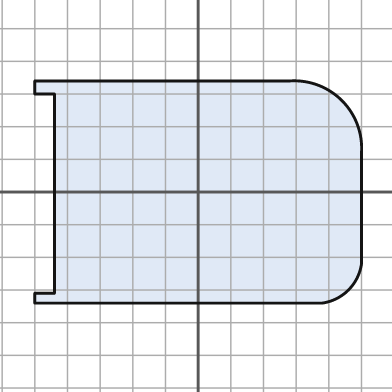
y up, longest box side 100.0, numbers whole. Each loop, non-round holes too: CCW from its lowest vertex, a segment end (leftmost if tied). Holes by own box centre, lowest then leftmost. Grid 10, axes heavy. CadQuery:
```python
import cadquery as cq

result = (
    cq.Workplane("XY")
    .moveTo(-50.0, -34.0)
    .lineTo(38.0, -34.0)
    .threePointArc((46.0, -30.0), (50.0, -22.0))
    .lineTo(50.0, 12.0)
    .threePointArc((44.0, 28.0), (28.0, 34.0))
    .lineTo(-50.0, 34.0)
    .lineTo(-50.0, 30.0)
    .lineTo(-44.0, 30.0)
    .lineTo(-44.0, -31.0)
    .lineTo(-50.0, -31.0)
    .close()
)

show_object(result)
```